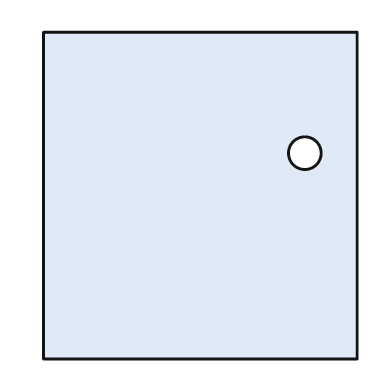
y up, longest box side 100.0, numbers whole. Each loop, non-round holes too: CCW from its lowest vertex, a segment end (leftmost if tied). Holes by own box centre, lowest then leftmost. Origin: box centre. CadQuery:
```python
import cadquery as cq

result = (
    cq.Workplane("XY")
    .moveTo(-48.0, -50.0)
    .lineTo(48.0, -50.0)
    .lineTo(48.0, 50.0)
    .lineTo(-48.0, 50.0)
    .close()
    .moveTo(32.0, 13.0)
    .circle(5.0)
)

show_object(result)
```